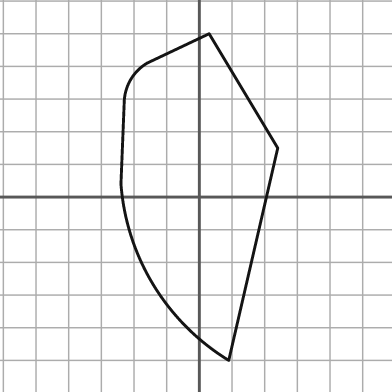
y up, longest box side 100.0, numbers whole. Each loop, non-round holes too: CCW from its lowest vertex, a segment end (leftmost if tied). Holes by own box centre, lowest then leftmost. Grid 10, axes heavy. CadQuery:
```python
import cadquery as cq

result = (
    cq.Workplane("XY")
    .moveTo(9.0, -50.0)
    .lineTo(24.0, 15.0)
    .lineTo(3.0, 50.0)
    .lineTo(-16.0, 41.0)
    .threePointArc((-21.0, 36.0), (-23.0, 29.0))
    .lineTo(-24.0, 4.0)
    .threePointArc((-14.0, -27.0), (9.0, -50.0))
    .close()
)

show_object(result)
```